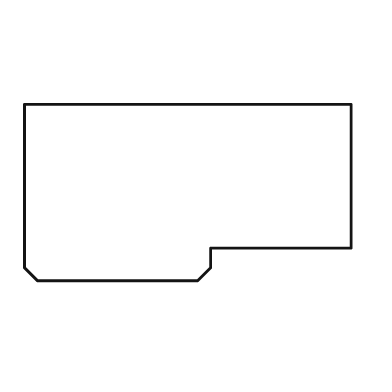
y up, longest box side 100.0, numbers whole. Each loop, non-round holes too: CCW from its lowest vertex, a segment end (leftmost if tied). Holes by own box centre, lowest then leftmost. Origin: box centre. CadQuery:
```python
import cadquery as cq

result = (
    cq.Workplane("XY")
    .moveTo(-46.0, -27.0)
    .lineTo(3.0, -27.0)
    .lineTo(7.0, -23.0)
    .lineTo(7.0, -17.0)
    .lineTo(50.0, -17.0)
    .lineTo(50.0, 27.0)
    .lineTo(-50.0, 27.0)
    .lineTo(-50.0, -23.0)
    .close()
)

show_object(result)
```